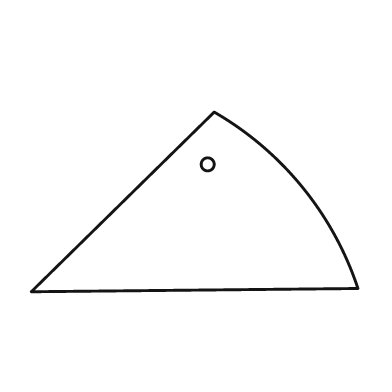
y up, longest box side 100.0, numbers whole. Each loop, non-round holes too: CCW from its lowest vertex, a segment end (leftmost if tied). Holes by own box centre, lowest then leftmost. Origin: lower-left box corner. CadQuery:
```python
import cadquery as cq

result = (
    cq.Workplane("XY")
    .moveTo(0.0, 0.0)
    .lineTo(100.0, 1.0)
    .threePointArc((83.0, 32.0), (56.0, 55.0))
    .close()
    .moveTo(54.0, 39.0)
    .circle(2.0)
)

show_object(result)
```